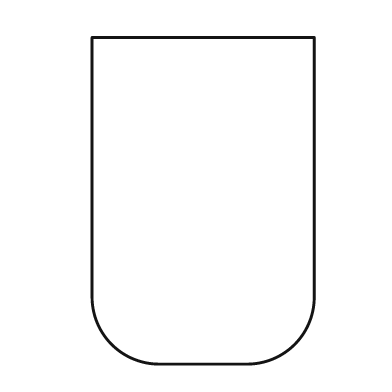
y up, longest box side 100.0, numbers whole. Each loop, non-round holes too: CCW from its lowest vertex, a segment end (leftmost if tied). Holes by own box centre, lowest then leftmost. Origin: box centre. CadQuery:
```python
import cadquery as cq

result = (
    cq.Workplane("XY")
    .moveTo(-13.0, -50.0)
    .lineTo(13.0, -50.0)
    .threePointArc((28.0, -44.0), (34.0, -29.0))
    .lineTo(34.0, 50.0)
    .lineTo(-34.0, 50.0)
    .lineTo(-34.0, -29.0)
    .threePointArc((-28.0, -44.0), (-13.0, -50.0))
    .close()
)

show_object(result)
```